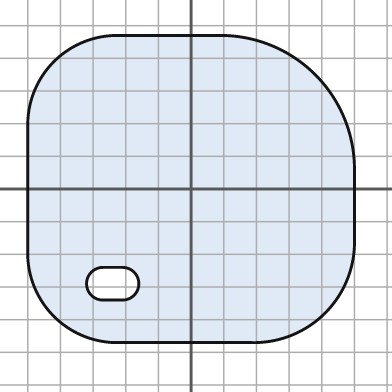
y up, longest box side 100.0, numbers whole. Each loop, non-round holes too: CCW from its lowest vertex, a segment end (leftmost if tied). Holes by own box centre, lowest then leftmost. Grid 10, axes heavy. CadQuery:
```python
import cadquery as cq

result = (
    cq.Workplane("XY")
    .moveTo(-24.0, -47.0)
    .lineTo(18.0, -47.0)
    .threePointArc((41.0, -38.0), (50.0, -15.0))
    .lineTo(50.0, 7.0)
    .threePointArc((38.0, 35.0), (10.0, 47.0))
    .lineTo(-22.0, 47.0)
    .threePointArc((-42.0, 39.0), (-50.0, 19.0))
    .lineTo(-50.0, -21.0)
    .threePointArc((-42.0, -39.0), (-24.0, -47.0))
    .close()
    .moveTo(-27.0, -34.0)
    .lineTo(-21.0, -34.0)
    .threePointArc((-16.0, -29.0), (-21.0, -24.0))
    .lineTo(-27.0, -24.0)
    .threePointArc((-32.0, -29.0), (-27.0, -34.0))
    .close()
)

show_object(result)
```